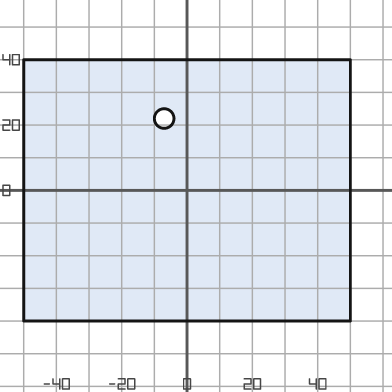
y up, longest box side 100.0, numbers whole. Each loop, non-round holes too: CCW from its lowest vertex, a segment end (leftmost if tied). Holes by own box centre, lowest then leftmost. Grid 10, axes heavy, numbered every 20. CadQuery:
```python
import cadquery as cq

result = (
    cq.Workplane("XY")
    .moveTo(-50.0, -40.0)
    .lineTo(50.0, -40.0)
    .lineTo(50.0, 40.0)
    .lineTo(-50.0, 40.0)
    .close()
    .moveTo(-7.0, 22.0)
    .circle(3.0)
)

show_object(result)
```